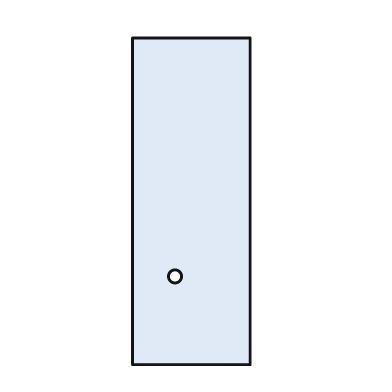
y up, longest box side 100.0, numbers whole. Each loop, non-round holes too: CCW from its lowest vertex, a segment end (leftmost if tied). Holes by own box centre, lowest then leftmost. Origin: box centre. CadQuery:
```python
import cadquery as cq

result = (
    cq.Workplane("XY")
    .moveTo(-18.0, -50.0)
    .lineTo(18.0, -50.0)
    .lineTo(18.0, 50.0)
    .lineTo(-18.0, 50.0)
    .close()
    .moveTo(-5.0, -23.0)
    .circle(2.0)
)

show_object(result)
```